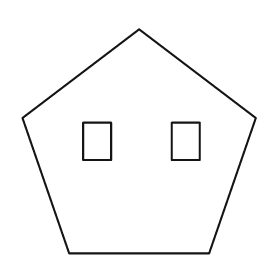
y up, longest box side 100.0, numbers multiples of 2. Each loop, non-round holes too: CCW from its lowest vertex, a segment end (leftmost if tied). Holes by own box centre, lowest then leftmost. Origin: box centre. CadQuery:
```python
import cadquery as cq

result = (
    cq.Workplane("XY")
    .moveTo(-30.0, -48.0)
    .lineTo(30.0, -48.0)
    .lineTo(50.0, 10.0)
    .lineTo(0.0, 48.0)
    .lineTo(-50.0, 10.0)
    .close()
    .moveTo(-24.0, -8.0)
    .lineTo(-12.0, -8.0)
    .lineTo(-12.0, 8.0)
    .lineTo(-24.0, 8.0)
    .close()
    .moveTo(14.0, -8.0)
    .lineTo(26.0, -8.0)
    .lineTo(26.0, 8.0)
    .lineTo(14.0, 8.0)
    .close()
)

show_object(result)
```